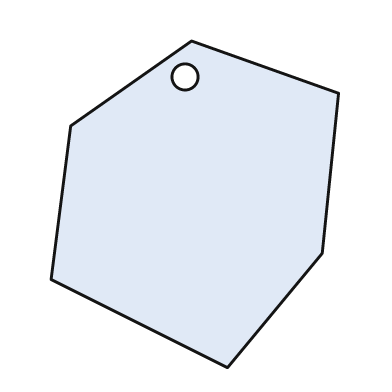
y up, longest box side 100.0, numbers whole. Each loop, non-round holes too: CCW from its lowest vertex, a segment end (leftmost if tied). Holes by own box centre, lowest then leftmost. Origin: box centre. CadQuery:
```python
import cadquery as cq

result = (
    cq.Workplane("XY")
    .moveTo(10.0, -50.0)
    .lineTo(39.0, -15.0)
    .lineTo(44.0, 34.0)
    .lineTo(-1.0, 50.0)
    .lineTo(-38.0, 24.0)
    .lineTo(-44.0, -23.0)
    .close()
    .moveTo(-3.0, 39.0)
    .circle(4.0)
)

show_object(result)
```